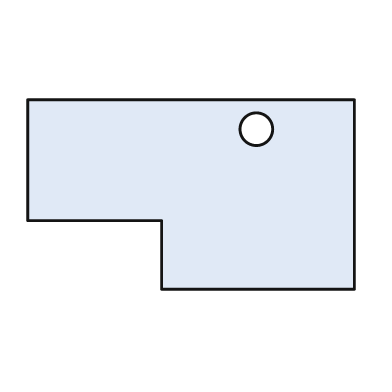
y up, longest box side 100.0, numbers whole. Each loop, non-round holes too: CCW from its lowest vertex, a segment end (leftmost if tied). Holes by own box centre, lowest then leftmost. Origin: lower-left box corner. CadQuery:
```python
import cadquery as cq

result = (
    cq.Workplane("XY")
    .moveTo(41.0, 0.0)
    .lineTo(100.0, 0.0)
    .lineTo(100.0, 58.0)
    .lineTo(0.0, 58.0)
    .lineTo(0.0, 21.0)
    .lineTo(41.0, 21.0)
    .close()
    .moveTo(70.0, 49.0)
    .circle(5.0)
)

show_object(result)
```